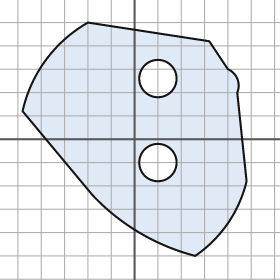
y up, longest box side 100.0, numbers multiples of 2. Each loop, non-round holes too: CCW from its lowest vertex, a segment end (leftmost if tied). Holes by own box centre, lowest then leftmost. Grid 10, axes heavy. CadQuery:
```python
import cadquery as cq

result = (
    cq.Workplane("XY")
    .moveTo(26.0, -50.0)
    .threePointArc((40.0, -36.0), (48.0, -18.0))
    .lineTo(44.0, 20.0)
    .threePointArc((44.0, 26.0), (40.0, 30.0))
    .lineTo(32.0, 42.0)
    .lineTo(-20.0, 50.0)
    .threePointArc((-38.0, 34.0), (-48.0, 12.0))
    .lineTo(-18.0, -24.0)
    .threePointArc((2.0, -40.0), (26.0, -50.0))
    .close()
    .moveTo(10.0, -10.0)
    .circle(8.0)
    .moveTo(10.0, 26.0)
    .circle(8.0)
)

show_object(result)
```